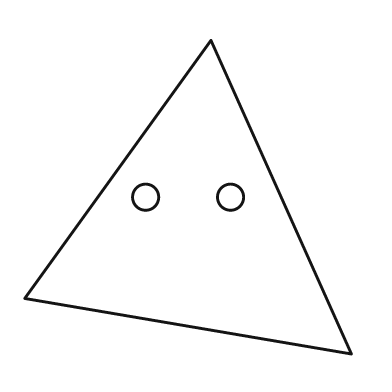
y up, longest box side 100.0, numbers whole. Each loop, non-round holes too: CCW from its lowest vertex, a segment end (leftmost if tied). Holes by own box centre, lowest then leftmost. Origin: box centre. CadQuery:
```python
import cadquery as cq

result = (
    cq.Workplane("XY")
    .moveTo(50.0, -48.0)
    .lineTo(7.0, 48.0)
    .lineTo(-50.0, -31.0)
    .close()
    .moveTo(-13.0, 0.0)
    .circle(4.0)
    .moveTo(13.0, 0.0)
    .circle(4.0)
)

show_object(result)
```